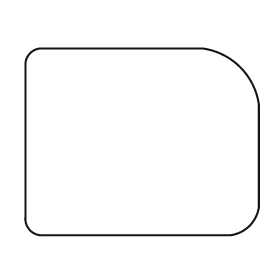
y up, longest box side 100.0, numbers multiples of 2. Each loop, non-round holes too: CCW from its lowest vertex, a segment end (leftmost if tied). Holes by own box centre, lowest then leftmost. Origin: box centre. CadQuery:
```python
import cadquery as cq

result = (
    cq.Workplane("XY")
    .moveTo(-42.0, -40.0)
    .lineTo(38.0, -40.0)
    .threePointArc((46.0, -36.0), (50.0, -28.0))
    .lineTo(50.0, 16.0)
    .threePointArc((42.0, 32.0), (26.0, 40.0))
    .lineTo(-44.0, 40.0)
    .threePointArc((-48.0, 38.0), (-50.0, 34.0))
    .lineTo(-50.0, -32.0)
    .threePointArc((-48.0, -38.0), (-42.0, -40.0))
    .close()
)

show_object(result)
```